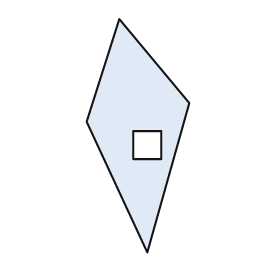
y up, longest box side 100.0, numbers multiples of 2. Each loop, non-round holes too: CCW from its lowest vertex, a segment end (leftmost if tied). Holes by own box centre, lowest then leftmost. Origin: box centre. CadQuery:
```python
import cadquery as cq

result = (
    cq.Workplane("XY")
    .moveTo(4.0, -50.0)
    .lineTo(22.0, 14.0)
    .lineTo(-8.0, 50.0)
    .lineTo(-22.0, 6.0)
    .close()
    .moveTo(-2.0, -10.0)
    .lineTo(10.0, -10.0)
    .lineTo(10.0, 2.0)
    .lineTo(-2.0, 2.0)
    .close()
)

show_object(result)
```